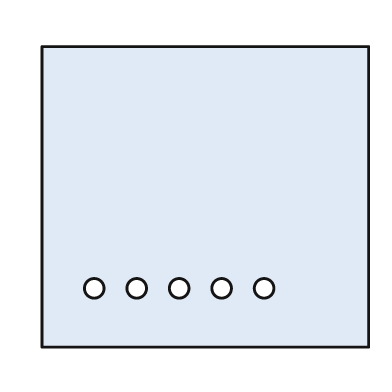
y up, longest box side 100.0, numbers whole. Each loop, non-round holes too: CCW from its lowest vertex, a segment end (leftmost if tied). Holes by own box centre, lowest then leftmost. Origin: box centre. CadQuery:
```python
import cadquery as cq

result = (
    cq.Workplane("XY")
    .moveTo(-50.0, -46.0)
    .lineTo(50.0, -46.0)
    .lineTo(50.0, 46.0)
    .lineTo(-50.0, 46.0)
    .close()
    .moveTo(-34.0, -28.0)
    .circle(3.0)
    .moveTo(-21.0, -28.0)
    .circle(3.0)
    .moveTo(-8.0, -28.0)
    .circle(3.0)
    .moveTo(5.0, -28.0)
    .circle(3.0)
    .moveTo(18.0, -28.0)
    .circle(3.0)
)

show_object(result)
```